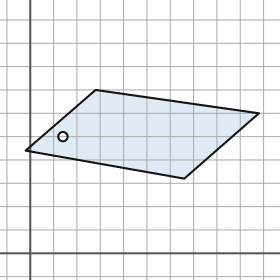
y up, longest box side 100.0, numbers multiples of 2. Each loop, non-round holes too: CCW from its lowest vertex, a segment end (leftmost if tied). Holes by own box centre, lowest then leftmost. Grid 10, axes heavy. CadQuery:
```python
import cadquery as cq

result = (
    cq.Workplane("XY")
    .moveTo(66.0, 32.0)
    .lineTo(98.0, 60.0)
    .lineTo(28.0, 70.0)
    .lineTo(-2.0, 44.0)
    .close()
    .moveTo(14.0, 50.0)
    .circle(2.0)
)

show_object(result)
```